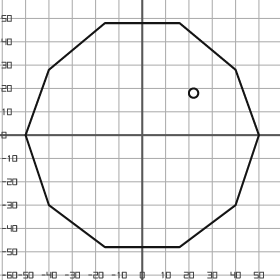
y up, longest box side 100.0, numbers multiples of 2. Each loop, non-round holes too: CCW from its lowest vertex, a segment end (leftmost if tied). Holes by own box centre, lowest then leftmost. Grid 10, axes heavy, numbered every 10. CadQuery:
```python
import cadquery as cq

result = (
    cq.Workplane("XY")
    .moveTo(-16.0, -48.0)
    .lineTo(16.0, -48.0)
    .lineTo(40.0, -30.0)
    .lineTo(50.0, 0.0)
    .lineTo(40.0, 28.0)
    .lineTo(16.0, 48.0)
    .lineTo(-16.0, 48.0)
    .lineTo(-40.0, 28.0)
    .lineTo(-50.0, 0.0)
    .lineTo(-40.0, -30.0)
    .close()
    .moveTo(22.0, 18.0)
    .circle(2.0)
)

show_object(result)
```